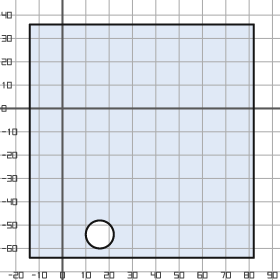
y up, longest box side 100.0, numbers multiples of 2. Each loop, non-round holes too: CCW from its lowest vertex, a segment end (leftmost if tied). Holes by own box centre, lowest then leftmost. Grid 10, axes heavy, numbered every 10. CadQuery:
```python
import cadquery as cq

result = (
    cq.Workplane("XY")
    .moveTo(-14.0, -64.0)
    .lineTo(82.0, -64.0)
    .lineTo(82.0, 36.0)
    .lineTo(-14.0, 36.0)
    .close()
    .moveTo(16.0, -54.0)
    .circle(6.0)
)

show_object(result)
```